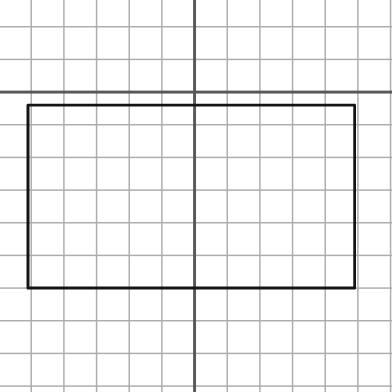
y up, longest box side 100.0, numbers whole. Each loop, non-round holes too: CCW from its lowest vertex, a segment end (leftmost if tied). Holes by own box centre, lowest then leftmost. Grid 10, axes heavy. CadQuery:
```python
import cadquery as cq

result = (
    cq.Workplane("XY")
    .moveTo(-51.0, -60.0)
    .lineTo(49.0, -60.0)
    .lineTo(49.0, -4.0)
    .lineTo(-51.0, -4.0)
    .close()
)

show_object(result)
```